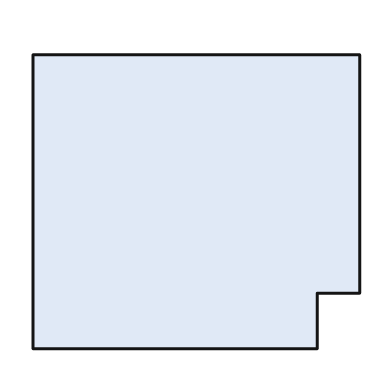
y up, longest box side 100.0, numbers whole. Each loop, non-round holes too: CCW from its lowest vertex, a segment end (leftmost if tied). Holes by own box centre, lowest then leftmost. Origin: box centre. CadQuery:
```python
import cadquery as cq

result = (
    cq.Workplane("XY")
    .moveTo(-50.0, -45.0)
    .lineTo(37.0, -45.0)
    .lineTo(37.0, -28.0)
    .lineTo(50.0, -28.0)
    .lineTo(50.0, 45.0)
    .lineTo(-50.0, 45.0)
    .close()
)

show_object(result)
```